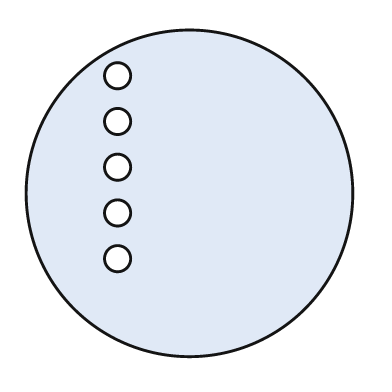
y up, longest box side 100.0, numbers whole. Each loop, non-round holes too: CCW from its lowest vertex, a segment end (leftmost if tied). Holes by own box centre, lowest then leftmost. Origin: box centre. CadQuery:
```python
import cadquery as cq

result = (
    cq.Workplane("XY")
    .moveTo(0.0, 0.0)
    .circle(50.0)
    .moveTo(-22.0, -20.0)
    .circle(4.0)
    .moveTo(-22.0, -6.0)
    .circle(4.0)
    .moveTo(-22.0, 8.0)
    .circle(4.0)
    .moveTo(-22.0, 22.0)
    .circle(4.0)
    .moveTo(-22.0, 36.0)
    .circle(4.0)
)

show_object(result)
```